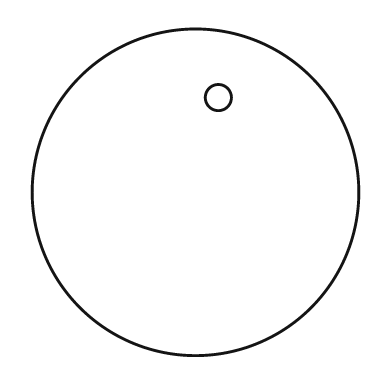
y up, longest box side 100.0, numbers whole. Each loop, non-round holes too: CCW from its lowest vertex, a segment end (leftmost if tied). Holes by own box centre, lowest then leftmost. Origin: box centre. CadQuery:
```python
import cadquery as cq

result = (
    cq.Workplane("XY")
    .moveTo(0.0, 0.0)
    .circle(50.0)
    .moveTo(7.0, 29.0)
    .circle(4.0)
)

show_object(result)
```